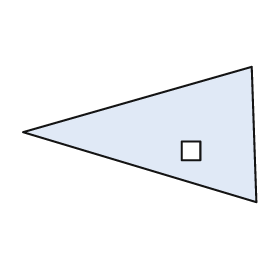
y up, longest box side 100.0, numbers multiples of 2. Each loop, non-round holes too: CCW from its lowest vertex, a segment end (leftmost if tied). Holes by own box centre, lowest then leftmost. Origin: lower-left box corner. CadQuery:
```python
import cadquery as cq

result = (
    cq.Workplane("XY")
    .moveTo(100.0, 0.0)
    .lineTo(98.0, 58.0)
    .lineTo(0.0, 30.0)
    .close()
    .moveTo(68.0, 18.0)
    .lineTo(76.0, 18.0)
    .lineTo(76.0, 26.0)
    .lineTo(68.0, 26.0)
    .close()
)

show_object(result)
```